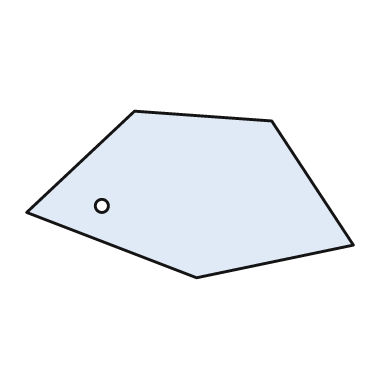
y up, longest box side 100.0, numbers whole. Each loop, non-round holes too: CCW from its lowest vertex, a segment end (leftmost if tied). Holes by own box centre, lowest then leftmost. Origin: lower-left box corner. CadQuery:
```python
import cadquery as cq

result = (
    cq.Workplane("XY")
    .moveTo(52.0, 0.0)
    .lineTo(100.0, 10.0)
    .lineTo(75.0, 48.0)
    .lineTo(33.0, 51.0)
    .lineTo(0.0, 20.0)
    .close()
    .moveTo(23.0, 22.0)
    .circle(2.0)
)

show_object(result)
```